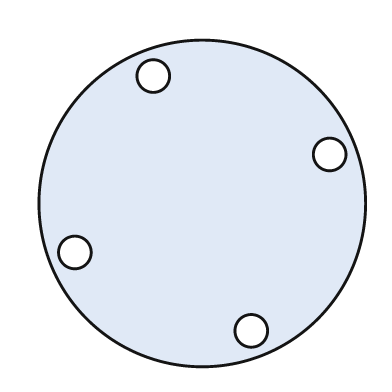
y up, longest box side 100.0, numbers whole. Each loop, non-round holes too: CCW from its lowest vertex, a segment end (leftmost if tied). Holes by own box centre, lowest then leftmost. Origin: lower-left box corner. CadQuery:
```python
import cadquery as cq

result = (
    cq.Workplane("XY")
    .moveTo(50.0, 50.0)
    .circle(50.0)
    .moveTo(65.0, 11.0)
    .circle(5.0)
    .moveTo(11.0, 35.0)
    .circle(5.0)
    .moveTo(89.0, 65.0)
    .circle(5.0)
    .moveTo(35.0, 89.0)
    .circle(5.0)
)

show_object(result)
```